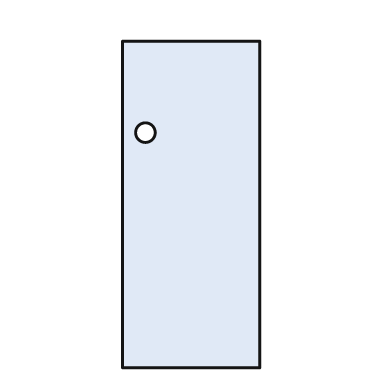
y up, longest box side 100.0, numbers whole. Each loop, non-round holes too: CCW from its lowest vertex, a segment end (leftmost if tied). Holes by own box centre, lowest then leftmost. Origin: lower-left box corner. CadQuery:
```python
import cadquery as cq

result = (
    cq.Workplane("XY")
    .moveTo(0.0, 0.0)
    .lineTo(42.0, 0.0)
    .lineTo(42.0, 100.0)
    .lineTo(0.0, 100.0)
    .close()
    .moveTo(7.0, 72.0)
    .circle(3.0)
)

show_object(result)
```